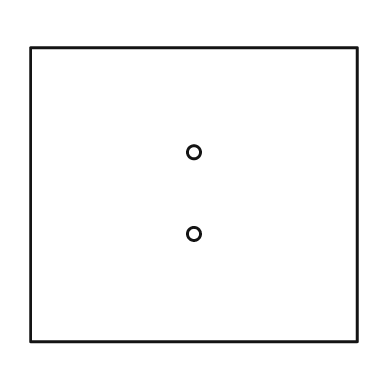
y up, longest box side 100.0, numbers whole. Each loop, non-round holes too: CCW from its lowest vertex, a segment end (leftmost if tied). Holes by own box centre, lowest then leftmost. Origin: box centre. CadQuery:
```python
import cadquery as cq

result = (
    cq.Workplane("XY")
    .moveTo(-50.0, -45.0)
    .lineTo(50.0, -45.0)
    .lineTo(50.0, 45.0)
    .lineTo(-50.0, 45.0)
    .close()
    .moveTo(0.0, -12.0)
    .circle(2.0)
    .moveTo(0.0, 13.0)
    .circle(2.0)
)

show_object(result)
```